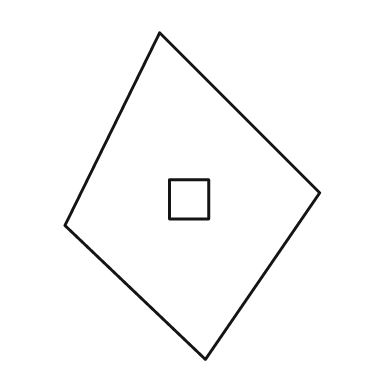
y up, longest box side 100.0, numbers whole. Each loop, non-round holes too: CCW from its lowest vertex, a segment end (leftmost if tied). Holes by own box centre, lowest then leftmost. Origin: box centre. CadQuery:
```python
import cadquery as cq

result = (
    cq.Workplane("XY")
    .moveTo(4.0, -50.0)
    .lineTo(39.0, 1.0)
    .lineTo(-10.0, 50.0)
    .lineTo(-39.0, -9.0)
    .close()
    .moveTo(-7.0, -7.0)
    .lineTo(5.0, -7.0)
    .lineTo(5.0, 5.0)
    .lineTo(-7.0, 5.0)
    .close()
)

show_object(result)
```